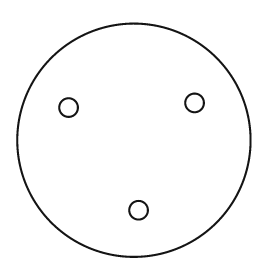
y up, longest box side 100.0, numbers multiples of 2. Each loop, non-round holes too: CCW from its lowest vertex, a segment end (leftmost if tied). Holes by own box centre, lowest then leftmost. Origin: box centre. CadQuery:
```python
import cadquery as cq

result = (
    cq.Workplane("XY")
    .moveTo(0.0, 0.0)
    .circle(50.0)
    .moveTo(2.0, -30.0)
    .circle(4.0)
    .moveTo(-28.0, 14.0)
    .circle(4.0)
    .moveTo(26.0, 16.0)
    .circle(4.0)
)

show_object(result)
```